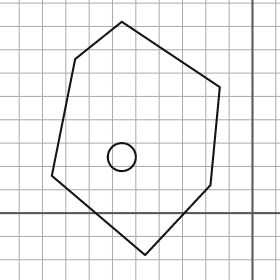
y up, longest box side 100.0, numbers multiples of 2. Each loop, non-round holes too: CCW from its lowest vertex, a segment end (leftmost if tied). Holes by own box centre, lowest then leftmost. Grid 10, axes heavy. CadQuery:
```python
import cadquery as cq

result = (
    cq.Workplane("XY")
    .moveTo(-46.0, -18.0)
    .lineTo(-18.0, 12.0)
    .lineTo(-14.0, 54.0)
    .lineTo(-56.0, 82.0)
    .lineTo(-76.0, 66.0)
    .lineTo(-86.0, 16.0)
    .close()
    .moveTo(-56.0, 24.0)
    .circle(6.0)
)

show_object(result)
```